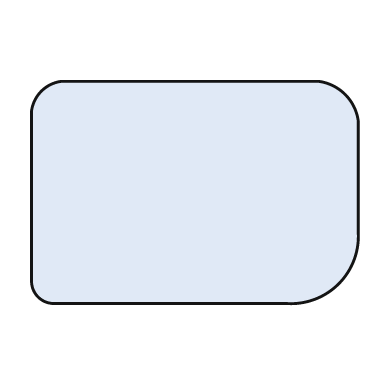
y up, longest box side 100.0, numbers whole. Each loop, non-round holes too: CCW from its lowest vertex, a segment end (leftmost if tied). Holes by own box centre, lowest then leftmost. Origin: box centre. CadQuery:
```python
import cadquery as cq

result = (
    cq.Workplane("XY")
    .moveTo(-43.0, -34.0)
    .lineTo(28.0, -34.0)
    .threePointArc((44.0, -28.0), (50.0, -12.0))
    .lineTo(50.0, 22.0)
    .threePointArc((46.0, 30.0), (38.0, 34.0))
    .lineTo(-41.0, 34.0)
    .threePointArc((-47.0, 31.0), (-50.0, 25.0))
    .lineTo(-50.0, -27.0)
    .threePointArc((-48.0, -32.0), (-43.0, -34.0))
    .close()
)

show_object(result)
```